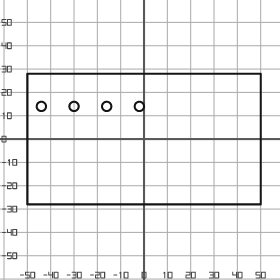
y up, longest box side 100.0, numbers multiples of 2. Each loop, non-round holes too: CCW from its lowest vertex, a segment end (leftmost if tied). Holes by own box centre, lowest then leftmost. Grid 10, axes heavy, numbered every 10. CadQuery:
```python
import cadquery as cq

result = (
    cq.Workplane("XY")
    .moveTo(-50.0, -28.0)
    .lineTo(50.0, -28.0)
    .lineTo(50.0, 28.0)
    .lineTo(-50.0, 28.0)
    .close()
    .moveTo(-44.0, 14.0)
    .circle(2.0)
    .moveTo(-30.0, 14.0)
    .circle(2.0)
    .moveTo(-16.0, 14.0)
    .circle(2.0)
    .moveTo(-2.0, 14.0)
    .circle(2.0)
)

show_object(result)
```